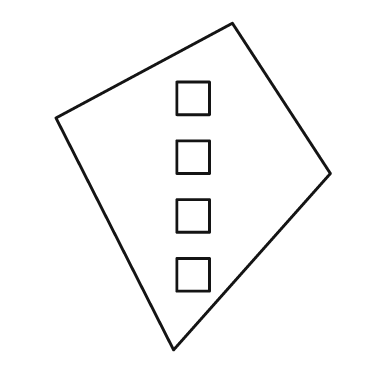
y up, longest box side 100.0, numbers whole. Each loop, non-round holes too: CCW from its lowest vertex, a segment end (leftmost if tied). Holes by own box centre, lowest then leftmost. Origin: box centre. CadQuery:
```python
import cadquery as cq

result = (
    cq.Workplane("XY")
    .moveTo(-6.0, -50.0)
    .lineTo(42.0, 4.0)
    .lineTo(12.0, 50.0)
    .lineTo(-42.0, 21.0)
    .close()
    .moveTo(-5.0, -32.0)
    .lineTo(5.0, -32.0)
    .lineTo(5.0, -22.0)
    .lineTo(-5.0, -22.0)
    .close()
    .moveTo(-5.0, -14.0)
    .lineTo(5.0, -14.0)
    .lineTo(5.0, -4.0)
    .lineTo(-5.0, -4.0)
    .close()
    .moveTo(-5.0, 4.0)
    .lineTo(5.0, 4.0)
    .lineTo(5.0, 14.0)
    .lineTo(-5.0, 14.0)
    .close()
    .moveTo(-5.0, 22.0)
    .lineTo(5.0, 22.0)
    .lineTo(5.0, 32.0)
    .lineTo(-5.0, 32.0)
    .close()
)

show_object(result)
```